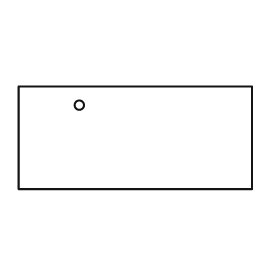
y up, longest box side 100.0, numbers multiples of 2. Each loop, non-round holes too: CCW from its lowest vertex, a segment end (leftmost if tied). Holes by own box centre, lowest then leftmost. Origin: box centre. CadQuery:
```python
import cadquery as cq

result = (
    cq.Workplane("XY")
    .moveTo(-50.0, -22.0)
    .lineTo(50.0, -22.0)
    .lineTo(50.0, 22.0)
    .lineTo(-50.0, 22.0)
    .close()
    .moveTo(-24.0, 14.0)
    .circle(2.0)
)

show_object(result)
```